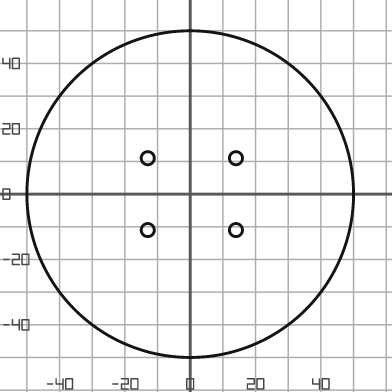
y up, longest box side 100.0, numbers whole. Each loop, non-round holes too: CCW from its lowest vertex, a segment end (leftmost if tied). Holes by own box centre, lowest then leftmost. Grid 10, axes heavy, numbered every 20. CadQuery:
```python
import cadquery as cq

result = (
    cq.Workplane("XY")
    .moveTo(0.0, 0.0)
    .circle(50.0)
    .moveTo(-13.0, -11.0)
    .circle(2.0)
    .moveTo(14.0, -11.0)
    .circle(2.0)
    .moveTo(-13.0, 11.0)
    .circle(2.0)
    .moveTo(14.0, 11.0)
    .circle(2.0)
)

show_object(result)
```